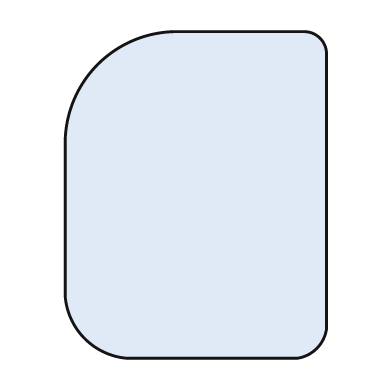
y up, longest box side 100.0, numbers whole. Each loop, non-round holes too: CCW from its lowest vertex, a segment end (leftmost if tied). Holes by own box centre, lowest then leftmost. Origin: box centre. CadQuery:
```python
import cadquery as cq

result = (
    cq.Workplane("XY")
    .moveTo(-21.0, -50.0)
    .lineTo(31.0, -50.0)
    .threePointArc((37.0, -47.0), (40.0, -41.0))
    .lineTo(40.0, 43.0)
    .threePointArc((38.0, 48.0), (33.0, 50.0))
    .lineTo(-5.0, 50.0)
    .threePointArc((-30.0, 40.0), (-40.0, 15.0))
    .lineTo(-40.0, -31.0)
    .threePointArc((-34.0, -44.0), (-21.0, -50.0))
    .close()
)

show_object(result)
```